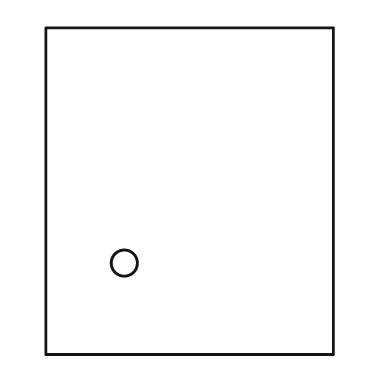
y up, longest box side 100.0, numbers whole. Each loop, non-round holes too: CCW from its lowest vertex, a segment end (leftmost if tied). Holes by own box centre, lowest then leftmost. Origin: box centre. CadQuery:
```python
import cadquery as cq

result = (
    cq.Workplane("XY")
    .moveTo(-44.0, -50.0)
    .lineTo(44.0, -50.0)
    .lineTo(44.0, 50.0)
    .lineTo(-44.0, 50.0)
    .close()
    .moveTo(-20.0, -22.0)
    .circle(4.0)
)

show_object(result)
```